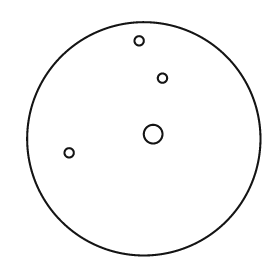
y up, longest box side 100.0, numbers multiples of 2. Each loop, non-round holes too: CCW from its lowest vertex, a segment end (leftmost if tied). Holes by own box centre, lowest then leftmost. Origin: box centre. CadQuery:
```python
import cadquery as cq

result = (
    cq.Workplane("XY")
    .moveTo(0.0, 0.0)
    .circle(50.0)
    .moveTo(-32.0, -6.0)
    .circle(2.0)
    .moveTo(4.0, 2.0)
    .circle(4.0)
    .moveTo(8.0, 26.0)
    .circle(2.0)
    .moveTo(-2.0, 42.0)
    .circle(2.0)
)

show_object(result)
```